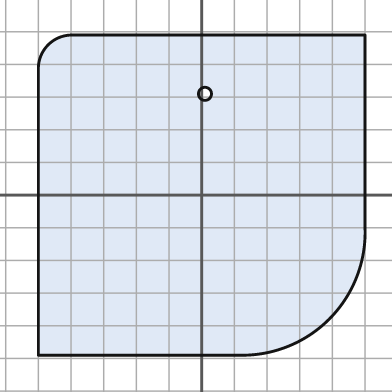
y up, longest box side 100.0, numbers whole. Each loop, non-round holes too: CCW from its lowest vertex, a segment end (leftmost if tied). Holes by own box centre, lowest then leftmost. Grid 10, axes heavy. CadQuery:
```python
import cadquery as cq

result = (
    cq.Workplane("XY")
    .moveTo(-50.0, -49.0)
    .lineTo(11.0, -49.0)
    .threePointArc((39.0, -38.0), (50.0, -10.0))
    .lineTo(50.0, 49.0)
    .lineTo(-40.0, 49.0)
    .threePointArc((-47.0, 46.0), (-50.0, 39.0))
    .close()
    .moveTo(1.0, 31.0)
    .circle(2.0)
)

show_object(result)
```